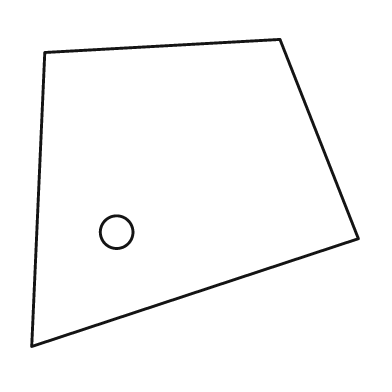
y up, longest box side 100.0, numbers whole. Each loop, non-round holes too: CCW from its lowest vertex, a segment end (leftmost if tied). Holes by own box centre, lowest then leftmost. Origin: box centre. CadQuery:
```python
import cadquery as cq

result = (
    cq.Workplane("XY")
    .moveTo(-50.0, -47.0)
    .lineTo(50.0, -14.0)
    .lineTo(26.0, 47.0)
    .lineTo(-46.0, 43.0)
    .close()
    .moveTo(-24.0, -12.0)
    .circle(5.0)
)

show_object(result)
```